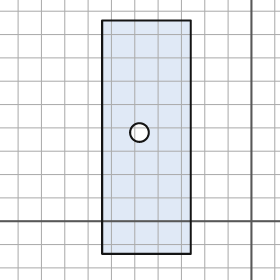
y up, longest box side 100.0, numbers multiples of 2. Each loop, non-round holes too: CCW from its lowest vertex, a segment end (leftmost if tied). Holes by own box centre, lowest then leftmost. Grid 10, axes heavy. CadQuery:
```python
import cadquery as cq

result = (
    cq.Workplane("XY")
    .moveTo(-64.0, -14.0)
    .lineTo(-26.0, -14.0)
    .lineTo(-26.0, 86.0)
    .lineTo(-64.0, 86.0)
    .close()
    .moveTo(-48.0, 38.0)
    .circle(4.0)
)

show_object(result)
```